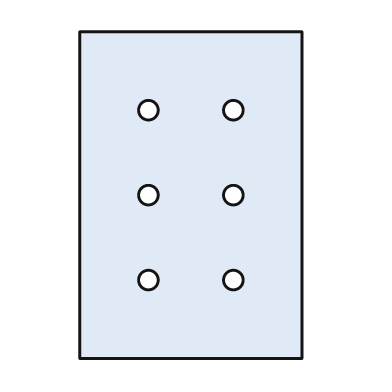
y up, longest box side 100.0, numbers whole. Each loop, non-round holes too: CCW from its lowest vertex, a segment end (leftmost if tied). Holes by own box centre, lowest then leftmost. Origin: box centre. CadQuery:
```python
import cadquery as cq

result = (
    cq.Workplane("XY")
    .moveTo(-34.0, -50.0)
    .lineTo(34.0, -50.0)
    .lineTo(34.0, 50.0)
    .lineTo(-34.0, 50.0)
    .close()
    .moveTo(-13.0, -26.0)
    .circle(3.0)
    .moveTo(13.0, -26.0)
    .circle(3.0)
    .moveTo(-13.0, 0.0)
    .circle(3.0)
    .moveTo(13.0, 0.0)
    .circle(3.0)
    .moveTo(-13.0, 26.0)
    .circle(3.0)
    .moveTo(13.0, 26.0)
    .circle(3.0)
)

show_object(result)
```